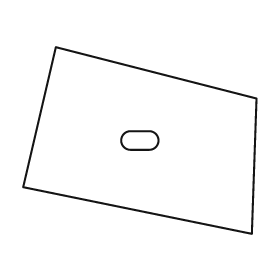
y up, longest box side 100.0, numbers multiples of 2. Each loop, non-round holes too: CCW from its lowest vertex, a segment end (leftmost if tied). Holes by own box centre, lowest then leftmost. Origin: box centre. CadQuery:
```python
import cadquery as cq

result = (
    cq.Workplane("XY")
    .moveTo(48.0, -40.0)
    .lineTo(50.0, 18.0)
    .lineTo(-36.0, 40.0)
    .lineTo(-50.0, -20.0)
    .close()
    .moveTo(-4.0, -4.0)
    .lineTo(4.0, -4.0)
    .threePointArc((8.0, 0.0), (4.0, 4.0))
    .lineTo(-4.0, 4.0)
    .threePointArc((-8.0, 0.0), (-4.0, -4.0))
    .close()
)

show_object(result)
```